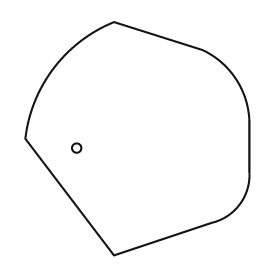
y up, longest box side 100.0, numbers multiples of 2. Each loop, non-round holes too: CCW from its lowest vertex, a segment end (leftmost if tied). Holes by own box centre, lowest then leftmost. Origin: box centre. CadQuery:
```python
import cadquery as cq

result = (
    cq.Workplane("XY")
    .moveTo(-10.0, -50.0)
    .lineTo(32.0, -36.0)
    .threePointArc((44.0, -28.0), (48.0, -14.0))
    .lineTo(48.0, 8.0)
    .threePointArc((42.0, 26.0), (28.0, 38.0))
    .lineTo(-10.0, 50.0)
    .threePointArc((-36.0, 30.0), (-48.0, 0.0))
    .close()
    .moveTo(-26.0, -4.0)
    .circle(2.0)
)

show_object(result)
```